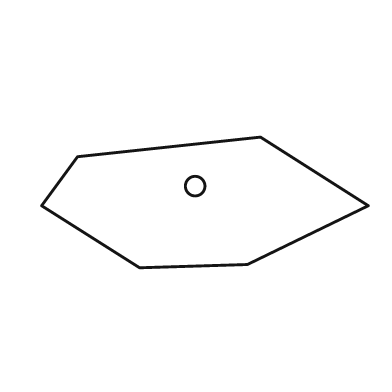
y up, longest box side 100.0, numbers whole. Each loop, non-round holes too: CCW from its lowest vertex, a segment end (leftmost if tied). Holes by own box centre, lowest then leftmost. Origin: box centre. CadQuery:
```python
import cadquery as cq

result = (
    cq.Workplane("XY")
    .moveTo(-20.0, -20.0)
    .lineTo(13.0, -19.0)
    .lineTo(50.0, -1.0)
    .lineTo(17.0, 20.0)
    .lineTo(-39.0, 14.0)
    .lineTo(-50.0, -1.0)
    .close()
    .moveTo(-3.0, 5.0)
    .circle(3.0)
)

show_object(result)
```